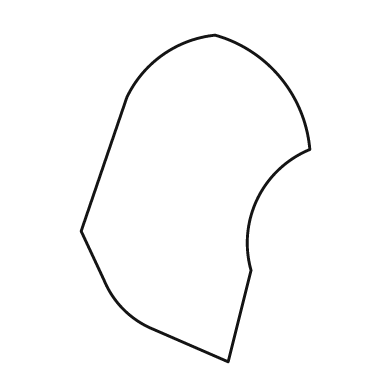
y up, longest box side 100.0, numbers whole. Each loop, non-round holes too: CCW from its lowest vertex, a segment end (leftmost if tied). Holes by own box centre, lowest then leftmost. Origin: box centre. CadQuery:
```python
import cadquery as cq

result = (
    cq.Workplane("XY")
    .moveTo(10.0, -50.0)
    .lineTo(17.0, -22.0)
    .threePointArc((19.0, 0.0), (35.0, 15.0))
    .threePointArc((26.0, 37.0), (6.0, 50.0))
    .threePointArc((-10.0, 44.0), (-21.0, 31.0))
    .lineTo(-35.0, -10.0)
    .lineTo(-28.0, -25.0)
    .threePointArc((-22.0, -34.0), (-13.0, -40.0))
    .close()
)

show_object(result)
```